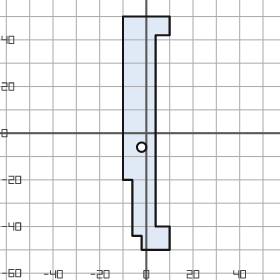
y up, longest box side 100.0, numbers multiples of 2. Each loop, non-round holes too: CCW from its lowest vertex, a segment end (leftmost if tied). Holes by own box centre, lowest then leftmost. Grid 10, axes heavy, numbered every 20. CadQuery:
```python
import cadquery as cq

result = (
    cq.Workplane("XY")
    .moveTo(-2.0, -50.0)
    .lineTo(10.0, -50.0)
    .lineTo(10.0, -40.0)
    .lineTo(4.0, -40.0)
    .lineTo(4.0, 42.0)
    .lineTo(10.0, 42.0)
    .lineTo(10.0, 50.0)
    .lineTo(-10.0, 50.0)
    .lineTo(-10.0, -20.0)
    .lineTo(-6.0, -20.0)
    .lineTo(-6.0, -44.0)
    .lineTo(-2.0, -44.0)
    .close()
    .moveTo(-2.0, -6.0)
    .circle(2.0)
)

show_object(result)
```